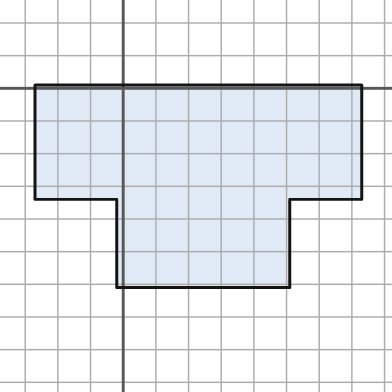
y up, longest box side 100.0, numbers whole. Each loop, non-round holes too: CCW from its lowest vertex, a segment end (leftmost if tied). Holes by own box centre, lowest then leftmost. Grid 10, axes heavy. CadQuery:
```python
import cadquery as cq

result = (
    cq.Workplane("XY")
    .moveTo(-2.0, -61.0)
    .lineTo(51.0, -61.0)
    .lineTo(51.0, -34.0)
    .lineTo(73.0, -34.0)
    .lineTo(73.0, 1.0)
    .lineTo(-27.0, 1.0)
    .lineTo(-27.0, -34.0)
    .lineTo(-2.0, -34.0)
    .close()
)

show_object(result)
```